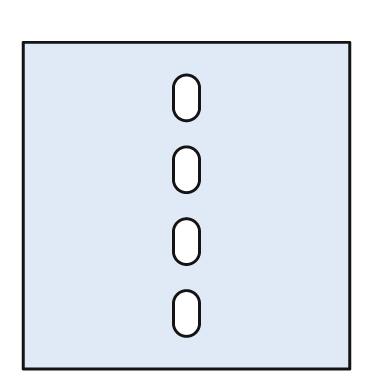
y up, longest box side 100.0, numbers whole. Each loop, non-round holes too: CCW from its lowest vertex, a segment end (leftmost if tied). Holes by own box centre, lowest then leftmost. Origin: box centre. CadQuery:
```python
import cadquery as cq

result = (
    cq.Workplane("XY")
    .moveTo(-50.0, -50.0)
    .lineTo(50.0, -50.0)
    .lineTo(50.0, 50.0)
    .lineTo(-50.0, 50.0)
    .close()
    .moveTo(-4.0, -36.0)
    .threePointArc((0.0, -40.0), (4.0, -36.0))
    .lineTo(4.0, -30.0)
    .threePointArc((0.0, -26.0), (-4.0, -30.0))
    .close()
    .moveTo(-4.0, -14.0)
    .threePointArc((0.0, -18.0), (4.0, -14.0))
    .lineTo(4.0, -8.0)
    .threePointArc((0.0, -4.0), (-4.0, -8.0))
    .close()
    .moveTo(-4.0, 8.0)
    .threePointArc((0.0, 4.0), (4.0, 8.0))
    .lineTo(4.0, 14.0)
    .threePointArc((0.0, 18.0), (-4.0, 14.0))
    .close()
    .moveTo(-4.0, 30.0)
    .threePointArc((0.0, 26.0), (4.0, 30.0))
    .lineTo(4.0, 36.0)
    .threePointArc((0.0, 40.0), (-4.0, 36.0))
    .close()
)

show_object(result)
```